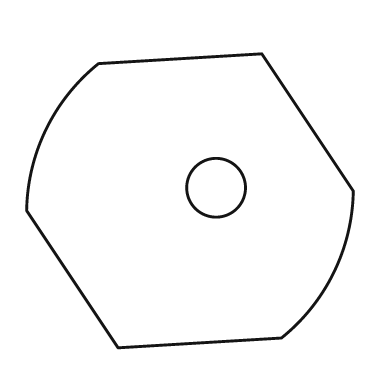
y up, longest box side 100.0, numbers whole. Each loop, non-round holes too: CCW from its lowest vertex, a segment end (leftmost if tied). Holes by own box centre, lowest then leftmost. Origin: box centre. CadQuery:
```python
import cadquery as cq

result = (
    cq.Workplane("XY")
    .moveTo(-22.0, -45.0)
    .lineTo(28.0, -42.0)
    .threePointArc((44.0, -22.0), (50.0, 3.0))
    .lineTo(22.0, 45.0)
    .lineTo(-28.0, 42.0)
    .threePointArc((-44.0, 22.0), (-50.0, -3.0))
    .close()
    .moveTo(8.0, 4.0)
    .circle(9.0)
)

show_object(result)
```